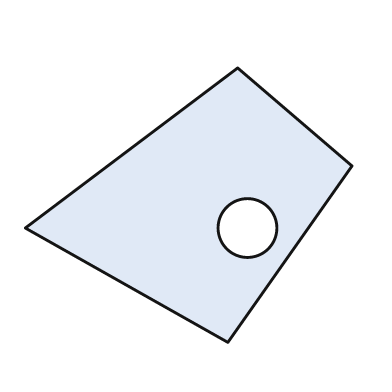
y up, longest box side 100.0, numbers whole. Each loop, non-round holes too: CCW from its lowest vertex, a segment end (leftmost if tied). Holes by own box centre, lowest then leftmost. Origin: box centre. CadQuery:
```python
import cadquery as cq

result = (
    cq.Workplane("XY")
    .moveTo(12.0, -42.0)
    .lineTo(50.0, 12.0)
    .lineTo(15.0, 42.0)
    .lineTo(-50.0, -7.0)
    .close()
    .moveTo(18.0, -7.0)
    .circle(9.0)
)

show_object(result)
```